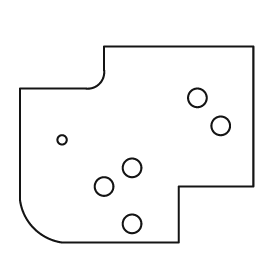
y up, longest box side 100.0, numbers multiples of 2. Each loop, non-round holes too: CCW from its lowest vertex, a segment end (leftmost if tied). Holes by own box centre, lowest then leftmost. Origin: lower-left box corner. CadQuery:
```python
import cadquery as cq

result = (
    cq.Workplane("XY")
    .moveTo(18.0, 0.0)
    .lineTo(68.0, 0.0)
    .lineTo(68.0, 24.0)
    .lineTo(100.0, 24.0)
    .lineTo(100.0, 84.0)
    .lineTo(36.0, 84.0)
    .lineTo(36.0, 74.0)
    .threePointArc((34.0, 68.0), (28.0, 66.0))
    .lineTo(0.0, 66.0)
    .lineTo(0.0, 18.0)
    .threePointArc((6.0, 6.0), (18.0, 0.0))
    .close()
    .moveTo(48.0, 8.0)
    .circle(4.0)
    .moveTo(36.0, 24.0)
    .circle(4.0)
    .moveTo(48.0, 32.0)
    .circle(4.0)
    .moveTo(18.0, 44.0)
    .circle(2.0)
    .moveTo(86.0, 50.0)
    .circle(4.0)
    .moveTo(76.0, 62.0)
    .circle(4.0)
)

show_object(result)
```